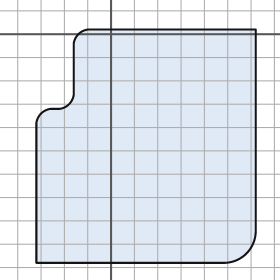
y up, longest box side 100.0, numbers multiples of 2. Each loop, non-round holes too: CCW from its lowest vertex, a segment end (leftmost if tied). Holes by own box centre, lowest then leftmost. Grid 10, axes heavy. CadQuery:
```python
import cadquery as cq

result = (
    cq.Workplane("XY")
    .moveTo(-32.0, -98.0)
    .lineTo(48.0, -98.0)
    .threePointArc((58.0, -94.0), (62.0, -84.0))
    .lineTo(62.0, 2.0)
    .lineTo(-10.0, 2.0)
    .threePointArc((-14.0, 0.0), (-16.0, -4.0))
    .lineTo(-16.0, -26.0)
    .threePointArc((-18.0, -30.0), (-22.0, -32.0))
    .lineTo(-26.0, -32.0)
    .threePointArc((-30.0, -34.0), (-32.0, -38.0))
    .close()
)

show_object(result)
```